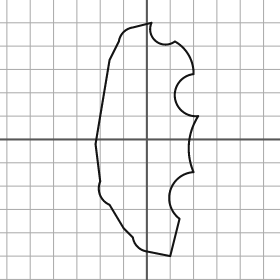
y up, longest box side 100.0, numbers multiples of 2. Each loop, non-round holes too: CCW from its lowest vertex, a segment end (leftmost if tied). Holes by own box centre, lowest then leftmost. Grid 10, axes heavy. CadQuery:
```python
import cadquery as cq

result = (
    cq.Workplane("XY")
    .moveTo(10.0, -50.0)
    .lineTo(14.0, -34.0)
    .threePointArc((10.0, -22.0), (20.0, -14.0))
    .threePointArc((18.0, -2.0), (22.0, 10.0))
    .threePointArc((12.0, 18.0), (20.0, 28.0))
    .threePointArc((18.0, 36.0), (12.0, 42.0))
    .threePointArc((4.0, 42.0), (2.0, 50.0))
    .lineTo(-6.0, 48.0)
    .threePointArc((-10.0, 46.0), (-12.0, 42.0))
    .lineTo(-16.0, 34.0)
    .lineTo(-22.0, -2.0)
    .lineTo(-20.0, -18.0)
    .threePointArc((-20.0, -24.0), (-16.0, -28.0))
    .lineTo(-10.0, -38.0)
    .lineTo(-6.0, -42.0)
    .threePointArc((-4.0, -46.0), (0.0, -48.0))
    .close()
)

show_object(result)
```